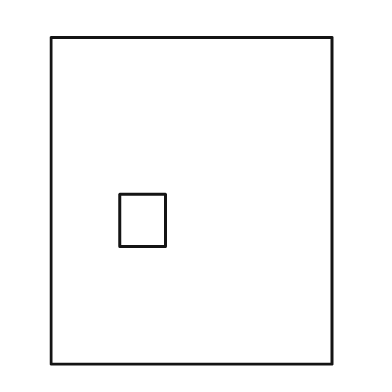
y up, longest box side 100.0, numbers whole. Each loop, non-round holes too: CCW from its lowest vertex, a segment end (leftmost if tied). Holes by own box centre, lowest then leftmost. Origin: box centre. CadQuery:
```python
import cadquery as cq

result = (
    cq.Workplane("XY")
    .moveTo(-43.0, -50.0)
    .lineTo(43.0, -50.0)
    .lineTo(43.0, 50.0)
    .lineTo(-43.0, 50.0)
    .close()
    .moveTo(-22.0, -14.0)
    .lineTo(-8.0, -14.0)
    .lineTo(-8.0, 2.0)
    .lineTo(-22.0, 2.0)
    .close()
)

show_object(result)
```